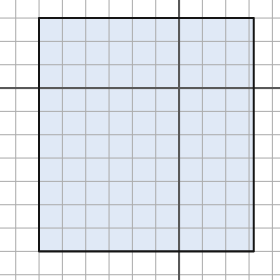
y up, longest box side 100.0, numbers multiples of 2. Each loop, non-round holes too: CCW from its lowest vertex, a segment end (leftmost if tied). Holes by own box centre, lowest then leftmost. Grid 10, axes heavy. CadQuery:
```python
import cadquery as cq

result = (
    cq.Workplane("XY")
    .moveTo(-60.0, -70.0)
    .lineTo(32.0, -70.0)
    .lineTo(32.0, 30.0)
    .lineTo(-60.0, 30.0)
    .close()
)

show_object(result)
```